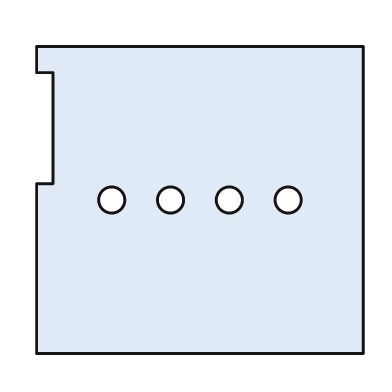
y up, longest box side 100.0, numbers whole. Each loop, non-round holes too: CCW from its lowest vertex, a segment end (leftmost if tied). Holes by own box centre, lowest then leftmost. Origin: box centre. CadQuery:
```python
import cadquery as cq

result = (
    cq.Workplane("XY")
    .moveTo(-50.0, -47.0)
    .lineTo(50.0, -47.0)
    .lineTo(50.0, 47.0)
    .lineTo(-50.0, 47.0)
    .lineTo(-50.0, 39.0)
    .lineTo(-45.0, 39.0)
    .lineTo(-45.0, 5.0)
    .lineTo(-50.0, 5.0)
    .close()
    .moveTo(-27.0, 0.0)
    .circle(4.0)
    .moveTo(-9.0, 0.0)
    .circle(4.0)
    .moveTo(9.0, 0.0)
    .circle(4.0)
    .moveTo(27.0, 0.0)
    .circle(4.0)
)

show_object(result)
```